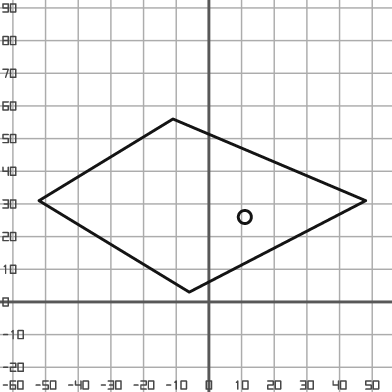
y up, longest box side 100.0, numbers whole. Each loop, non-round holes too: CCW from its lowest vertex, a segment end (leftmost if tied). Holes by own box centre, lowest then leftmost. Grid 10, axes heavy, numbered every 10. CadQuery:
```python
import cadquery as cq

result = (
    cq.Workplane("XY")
    .moveTo(-6.0, 3.0)
    .lineTo(48.0, 31.0)
    .lineTo(-11.0, 56.0)
    .lineTo(-52.0, 31.0)
    .close()
    .moveTo(11.0, 26.0)
    .circle(2.0)
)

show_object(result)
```